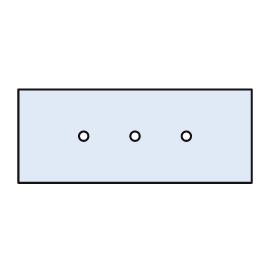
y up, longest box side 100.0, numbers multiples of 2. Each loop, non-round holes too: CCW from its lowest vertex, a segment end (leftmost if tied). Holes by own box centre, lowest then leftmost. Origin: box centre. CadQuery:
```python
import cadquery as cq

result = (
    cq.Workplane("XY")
    .moveTo(-50.0, -20.0)
    .lineTo(50.0, -20.0)
    .lineTo(50.0, 20.0)
    .lineTo(-50.0, 20.0)
    .close()
    .moveTo(-22.0, 0.0)
    .circle(2.0)
    .moveTo(0.0, 0.0)
    .circle(2.0)
    .moveTo(22.0, 0.0)
    .circle(2.0)
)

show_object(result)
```